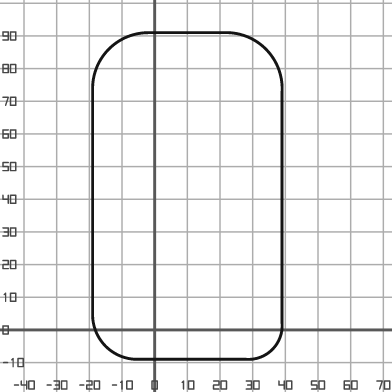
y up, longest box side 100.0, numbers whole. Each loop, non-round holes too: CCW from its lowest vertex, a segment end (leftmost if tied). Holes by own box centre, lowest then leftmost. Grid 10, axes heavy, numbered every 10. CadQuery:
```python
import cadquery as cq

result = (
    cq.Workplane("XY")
    .moveTo(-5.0, -9.0)
    .lineTo(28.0, -9.0)
    .threePointArc((36.0, -6.0), (39.0, 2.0))
    .lineTo(39.0, 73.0)
    .threePointArc((34.0, 86.0), (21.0, 91.0))
    .lineTo(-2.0, 91.0)
    .threePointArc((-14.0, 86.0), (-19.0, 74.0))
    .lineTo(-19.0, 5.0)
    .threePointArc((-15.0, -5.0), (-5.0, -9.0))
    .close()
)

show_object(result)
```